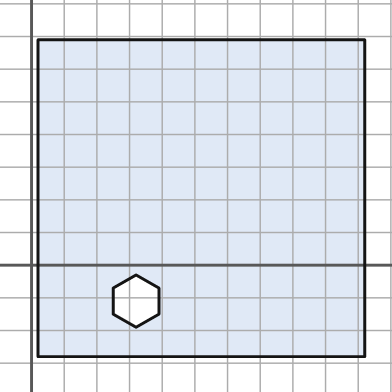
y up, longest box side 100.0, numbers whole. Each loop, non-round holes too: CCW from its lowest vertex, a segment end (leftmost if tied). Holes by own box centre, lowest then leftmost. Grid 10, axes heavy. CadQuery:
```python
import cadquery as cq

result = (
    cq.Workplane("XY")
    .moveTo(2.0, -28.0)
    .lineTo(102.0, -28.0)
    .lineTo(102.0, 69.0)
    .lineTo(2.0, 69.0)
    .close()
    .moveTo(32.0, -19.0)
    .lineTo(39.0, -15.0)
    .lineTo(39.0, -7.0)
    .lineTo(32.0, -3.0)
    .lineTo(25.0, -7.0)
    .lineTo(25.0, -15.0)
    .close()
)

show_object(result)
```